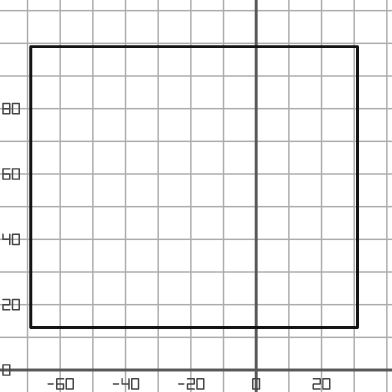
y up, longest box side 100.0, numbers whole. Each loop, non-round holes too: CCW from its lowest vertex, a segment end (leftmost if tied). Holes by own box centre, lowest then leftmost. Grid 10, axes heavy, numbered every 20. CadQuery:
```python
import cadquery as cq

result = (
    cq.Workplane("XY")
    .moveTo(-69.0, 13.0)
    .lineTo(31.0, 13.0)
    .lineTo(31.0, 99.0)
    .lineTo(-69.0, 99.0)
    .close()
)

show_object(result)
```